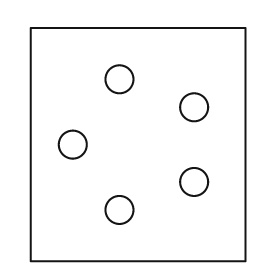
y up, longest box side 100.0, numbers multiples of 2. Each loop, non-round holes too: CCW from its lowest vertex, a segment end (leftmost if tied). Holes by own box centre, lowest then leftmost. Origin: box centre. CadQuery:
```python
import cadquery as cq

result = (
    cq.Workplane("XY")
    .moveTo(-46.0, -50.0)
    .lineTo(46.0, -50.0)
    .lineTo(46.0, 50.0)
    .lineTo(-46.0, 50.0)
    .close()
    .moveTo(-8.0, -28.0)
    .circle(6.0)
    .moveTo(24.0, -16.0)
    .circle(6.0)
    .moveTo(-28.0, 0.0)
    .circle(6.0)
    .moveTo(24.0, 16.0)
    .circle(6.0)
    .moveTo(-8.0, 28.0)
    .circle(6.0)
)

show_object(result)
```